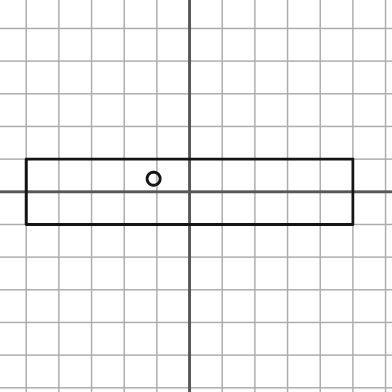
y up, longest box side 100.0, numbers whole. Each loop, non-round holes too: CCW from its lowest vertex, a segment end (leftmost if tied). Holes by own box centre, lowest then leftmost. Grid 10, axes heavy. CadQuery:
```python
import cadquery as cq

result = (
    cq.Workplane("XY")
    .moveTo(-50.0, -10.0)
    .lineTo(50.0, -10.0)
    .lineTo(50.0, 10.0)
    .lineTo(-50.0, 10.0)
    .close()
    .moveTo(-11.0, 4.0)
    .circle(2.0)
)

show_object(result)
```